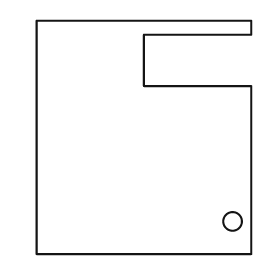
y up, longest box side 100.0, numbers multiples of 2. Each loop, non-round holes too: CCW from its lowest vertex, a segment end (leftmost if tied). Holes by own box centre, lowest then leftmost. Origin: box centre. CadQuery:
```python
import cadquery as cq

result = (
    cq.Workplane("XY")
    .moveTo(-46.0, -50.0)
    .lineTo(46.0, -50.0)
    .lineTo(46.0, 22.0)
    .lineTo(0.0, 22.0)
    .lineTo(0.0, 44.0)
    .lineTo(46.0, 44.0)
    .lineTo(46.0, 50.0)
    .lineTo(-46.0, 50.0)
    .close()
    .moveTo(38.0, -36.0)
    .circle(4.0)
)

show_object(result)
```